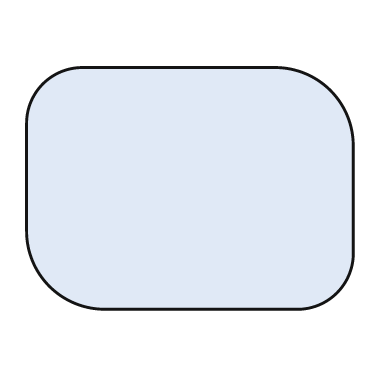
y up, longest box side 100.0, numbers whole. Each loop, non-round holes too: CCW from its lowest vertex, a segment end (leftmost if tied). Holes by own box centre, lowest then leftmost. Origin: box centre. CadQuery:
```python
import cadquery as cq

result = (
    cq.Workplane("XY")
    .moveTo(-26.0, -37.0)
    .lineTo(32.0, -37.0)
    .threePointArc((45.0, -32.0), (50.0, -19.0))
    .lineTo(50.0, 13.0)
    .threePointArc((43.0, 30.0), (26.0, 37.0))
    .lineTo(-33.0, 37.0)
    .threePointArc((-45.0, 32.0), (-50.0, 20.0))
    .lineTo(-50.0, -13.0)
    .threePointArc((-43.0, -30.0), (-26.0, -37.0))
    .close()
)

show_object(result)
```